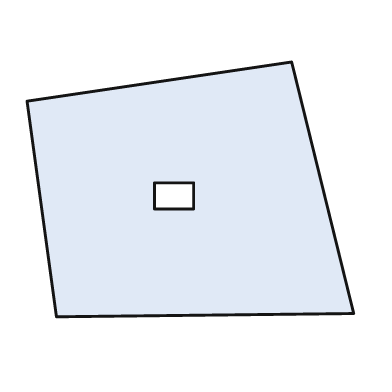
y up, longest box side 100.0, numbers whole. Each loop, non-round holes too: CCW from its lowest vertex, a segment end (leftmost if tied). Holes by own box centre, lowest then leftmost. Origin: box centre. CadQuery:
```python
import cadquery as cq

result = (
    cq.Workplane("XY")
    .moveTo(-41.0, -39.0)
    .lineTo(50.0, -38.0)
    .lineTo(31.0, 39.0)
    .lineTo(-50.0, 27.0)
    .close()
    .moveTo(-11.0, -6.0)
    .lineTo(1.0, -6.0)
    .lineTo(1.0, 2.0)
    .lineTo(-11.0, 2.0)
    .close()
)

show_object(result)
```